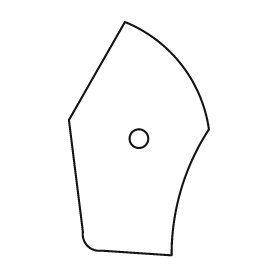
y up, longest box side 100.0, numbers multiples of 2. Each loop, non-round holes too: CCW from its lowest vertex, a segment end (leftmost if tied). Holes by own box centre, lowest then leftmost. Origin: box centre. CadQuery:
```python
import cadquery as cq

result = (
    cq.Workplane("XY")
    .moveTo(14.0, -50.0)
    .threePointArc((18.0, -22.0), (30.0, 4.0))
    .threePointArc((18.0, 32.0), (-6.0, 50.0))
    .lineTo(-30.0, 8.0)
    .lineTo(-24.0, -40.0)
    .threePointArc((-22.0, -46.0), (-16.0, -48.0))
    .close()
    .moveTo(0.0, 0.0)
    .circle(4.0)
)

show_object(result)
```